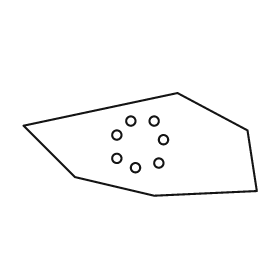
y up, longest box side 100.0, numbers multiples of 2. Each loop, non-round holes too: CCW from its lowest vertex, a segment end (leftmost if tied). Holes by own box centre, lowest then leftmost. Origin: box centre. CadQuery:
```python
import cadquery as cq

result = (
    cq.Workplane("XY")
    .moveTo(6.0, -22.0)
    .lineTo(50.0, -20.0)
    .lineTo(46.0, 6.0)
    .lineTo(16.0, 22.0)
    .lineTo(-50.0, 8.0)
    .lineTo(-28.0, -14.0)
    .close()
    .moveTo(-2.0, -10.0)
    .circle(2.0)
    .moveTo(8.0, -8.0)
    .circle(2.0)
    .moveTo(-10.0, -6.0)
    .circle(2.0)
    .moveTo(10.0, 2.0)
    .circle(2.0)
    .moveTo(-10.0, 4.0)
    .circle(2.0)
    .moveTo(-4.0, 10.0)
    .circle(2.0)
    .moveTo(6.0, 10.0)
    .circle(2.0)
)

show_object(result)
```